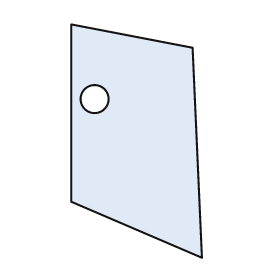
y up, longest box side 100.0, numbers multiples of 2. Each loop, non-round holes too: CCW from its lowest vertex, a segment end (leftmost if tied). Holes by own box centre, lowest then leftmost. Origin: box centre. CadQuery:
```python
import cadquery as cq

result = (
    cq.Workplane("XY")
    .moveTo(28.0, -50.0)
    .lineTo(24.0, 40.0)
    .lineTo(-28.0, 50.0)
    .lineTo(-28.0, -26.0)
    .close()
    .moveTo(-18.0, 18.0)
    .circle(6.0)
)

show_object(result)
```